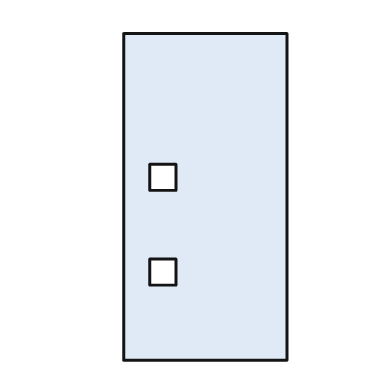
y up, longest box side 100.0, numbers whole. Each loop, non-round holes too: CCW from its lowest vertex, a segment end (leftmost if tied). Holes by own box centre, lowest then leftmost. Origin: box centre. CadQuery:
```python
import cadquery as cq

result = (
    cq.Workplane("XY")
    .moveTo(-25.0, -50.0)
    .lineTo(25.0, -50.0)
    .lineTo(25.0, 50.0)
    .lineTo(-25.0, 50.0)
    .close()
    .moveTo(-17.0, -27.0)
    .lineTo(-9.0, -27.0)
    .lineTo(-9.0, -19.0)
    .lineTo(-17.0, -19.0)
    .close()
    .moveTo(-17.0, 2.0)
    .lineTo(-9.0, 2.0)
    .lineTo(-9.0, 10.0)
    .lineTo(-17.0, 10.0)
    .close()
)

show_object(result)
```